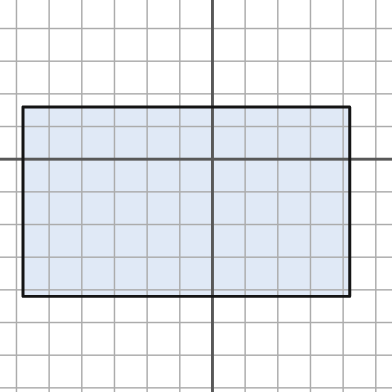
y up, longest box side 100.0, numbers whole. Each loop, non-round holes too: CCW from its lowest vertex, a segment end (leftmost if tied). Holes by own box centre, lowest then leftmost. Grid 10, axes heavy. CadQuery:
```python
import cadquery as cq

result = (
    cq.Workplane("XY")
    .moveTo(-58.0, -42.0)
    .lineTo(42.0, -42.0)
    .lineTo(42.0, 16.0)
    .lineTo(-58.0, 16.0)
    .close()
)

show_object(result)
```